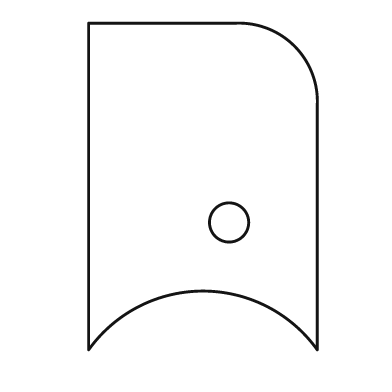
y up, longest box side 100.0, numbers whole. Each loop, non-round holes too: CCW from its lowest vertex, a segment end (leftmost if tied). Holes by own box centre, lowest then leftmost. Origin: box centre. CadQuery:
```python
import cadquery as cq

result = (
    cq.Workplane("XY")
    .moveTo(-35.0, -50.0)
    .threePointArc((0.0, -32.0), (35.0, -50.0))
    .lineTo(35.0, 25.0)
    .threePointArc((28.0, 43.0), (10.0, 50.0))
    .lineTo(-35.0, 50.0)
    .close()
    .moveTo(8.0, -11.0)
    .circle(6.0)
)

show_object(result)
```